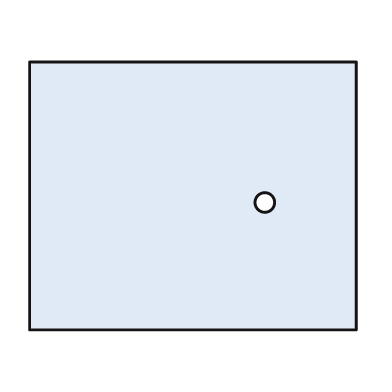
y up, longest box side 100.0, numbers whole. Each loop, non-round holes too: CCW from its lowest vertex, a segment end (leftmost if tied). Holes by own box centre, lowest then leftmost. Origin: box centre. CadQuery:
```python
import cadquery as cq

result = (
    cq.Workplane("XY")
    .moveTo(-50.0, -41.0)
    .lineTo(50.0, -41.0)
    .lineTo(50.0, 41.0)
    .lineTo(-50.0, 41.0)
    .close()
    .moveTo(22.0, -2.0)
    .circle(3.0)
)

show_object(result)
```